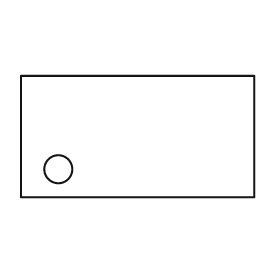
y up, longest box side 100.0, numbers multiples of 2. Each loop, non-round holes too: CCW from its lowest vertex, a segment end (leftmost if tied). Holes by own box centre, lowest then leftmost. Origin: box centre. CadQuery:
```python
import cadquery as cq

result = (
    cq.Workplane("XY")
    .moveTo(-50.0, -26.0)
    .lineTo(50.0, -26.0)
    .lineTo(50.0, 26.0)
    .lineTo(-50.0, 26.0)
    .close()
    .moveTo(-34.0, -14.0)
    .circle(6.0)
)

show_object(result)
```